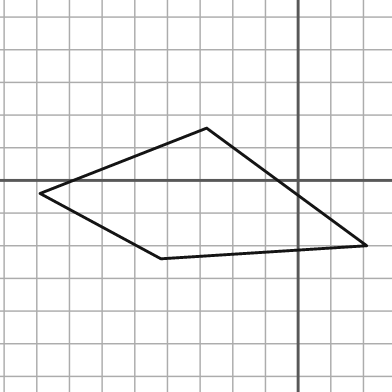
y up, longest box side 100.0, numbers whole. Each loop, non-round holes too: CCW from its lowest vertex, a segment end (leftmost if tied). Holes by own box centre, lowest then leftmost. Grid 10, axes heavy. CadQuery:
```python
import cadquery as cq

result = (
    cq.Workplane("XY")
    .moveTo(-42.0, -24.0)
    .lineTo(21.0, -20.0)
    .lineTo(-28.0, 16.0)
    .lineTo(-79.0, -4.0)
    .close()
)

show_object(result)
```